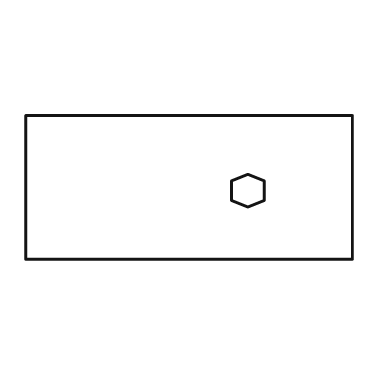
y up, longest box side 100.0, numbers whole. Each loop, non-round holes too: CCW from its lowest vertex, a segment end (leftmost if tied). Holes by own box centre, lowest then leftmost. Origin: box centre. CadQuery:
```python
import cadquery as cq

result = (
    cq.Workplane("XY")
    .moveTo(-50.0, -22.0)
    .lineTo(50.0, -22.0)
    .lineTo(50.0, 22.0)
    .lineTo(-50.0, 22.0)
    .close()
    .moveTo(18.0, -6.0)
    .lineTo(23.0, -4.0)
    .lineTo(23.0, 2.0)
    .lineTo(18.0, 4.0)
    .lineTo(13.0, 2.0)
    .lineTo(13.0, -4.0)
    .close()
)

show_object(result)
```